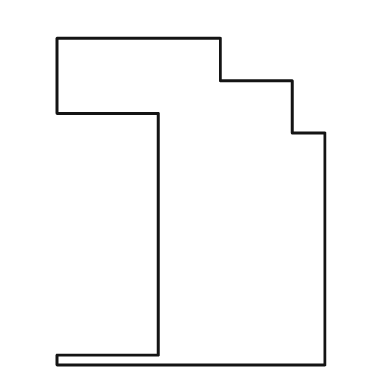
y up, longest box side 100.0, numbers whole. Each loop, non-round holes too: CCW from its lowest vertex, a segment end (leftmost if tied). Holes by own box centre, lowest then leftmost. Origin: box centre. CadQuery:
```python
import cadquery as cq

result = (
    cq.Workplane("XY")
    .moveTo(-41.0, -50.0)
    .lineTo(41.0, -50.0)
    .lineTo(41.0, 21.0)
    .lineTo(31.0, 21.0)
    .lineTo(31.0, 37.0)
    .lineTo(9.0, 37.0)
    .lineTo(9.0, 50.0)
    .lineTo(-41.0, 50.0)
    .lineTo(-41.0, 27.0)
    .lineTo(-10.0, 27.0)
    .lineTo(-10.0, -47.0)
    .lineTo(-41.0, -47.0)
    .close()
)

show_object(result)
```